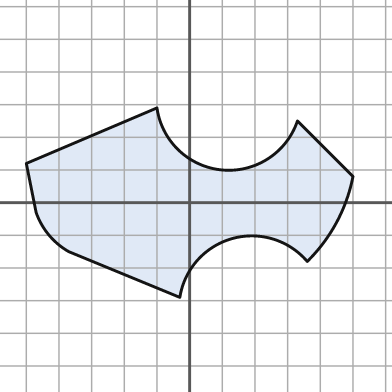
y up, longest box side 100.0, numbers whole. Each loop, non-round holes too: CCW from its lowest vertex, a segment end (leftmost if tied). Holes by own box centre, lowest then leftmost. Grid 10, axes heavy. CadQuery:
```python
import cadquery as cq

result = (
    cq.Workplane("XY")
    .moveTo(-3.0, -29.0)
    .threePointArc((13.0, -11.0), (36.0, -18.0))
    .threePointArc((45.0, -6.0), (50.0, 8.0))
    .lineTo(33.0, 25.0)
    .threePointArc((10.0, 10.0), (-10.0, 29.0))
    .lineTo(-50.0, 12.0)
    .lineTo(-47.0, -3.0)
    .threePointArc((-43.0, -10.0), (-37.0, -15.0))
    .close()
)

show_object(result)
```